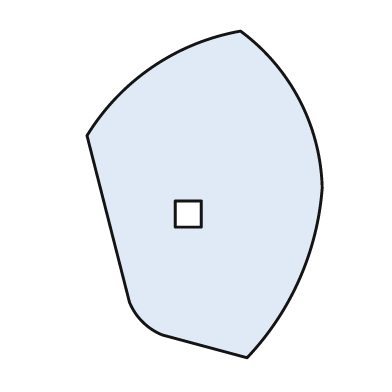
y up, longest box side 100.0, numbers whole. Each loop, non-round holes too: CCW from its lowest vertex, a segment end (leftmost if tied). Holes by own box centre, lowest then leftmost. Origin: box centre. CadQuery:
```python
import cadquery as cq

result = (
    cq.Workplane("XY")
    .moveTo(13.0, -50.0)
    .threePointArc((29.0, -26.0), (36.0, 2.0))
    .threePointArc((29.0, 29.0), (11.0, 50.0))
    .threePointArc((-16.0, 39.0), (-36.0, 18.0))
    .lineTo(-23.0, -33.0)
    .threePointArc((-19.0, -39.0), (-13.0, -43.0))
    .close()
    .moveTo(-9.0, -10.0)
    .lineTo(-1.0, -10.0)
    .lineTo(-1.0, -2.0)
    .lineTo(-9.0, -2.0)
    .close()
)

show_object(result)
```